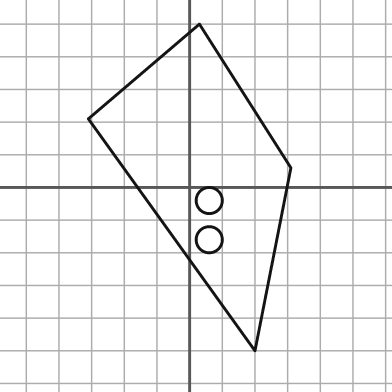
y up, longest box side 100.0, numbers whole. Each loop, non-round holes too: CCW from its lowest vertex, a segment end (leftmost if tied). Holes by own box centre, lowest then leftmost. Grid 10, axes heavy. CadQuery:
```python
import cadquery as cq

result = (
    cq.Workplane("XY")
    .moveTo(20.0, -50.0)
    .lineTo(31.0, 6.0)
    .lineTo(3.0, 50.0)
    .lineTo(-31.0, 21.0)
    .close()
    .moveTo(6.0, -16.0)
    .circle(4.0)
    .moveTo(6.0, -4.0)
    .circle(4.0)
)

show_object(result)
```